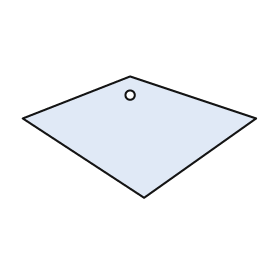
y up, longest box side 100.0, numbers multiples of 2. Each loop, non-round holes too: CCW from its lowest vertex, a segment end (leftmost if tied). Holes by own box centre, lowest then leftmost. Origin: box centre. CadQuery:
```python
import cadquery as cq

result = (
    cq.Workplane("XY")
    .moveTo(2.0, -26.0)
    .lineTo(50.0, 8.0)
    .lineTo(-4.0, 26.0)
    .lineTo(-50.0, 8.0)
    .close()
    .moveTo(-4.0, 18.0)
    .circle(2.0)
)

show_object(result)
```